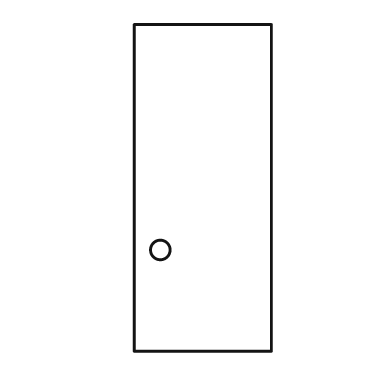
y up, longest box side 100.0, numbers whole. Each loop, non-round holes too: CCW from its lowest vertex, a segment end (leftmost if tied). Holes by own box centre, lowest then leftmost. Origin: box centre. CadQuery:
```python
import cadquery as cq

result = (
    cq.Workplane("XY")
    .moveTo(-21.0, -50.0)
    .lineTo(21.0, -50.0)
    .lineTo(21.0, 50.0)
    .lineTo(-21.0, 50.0)
    .close()
    .moveTo(-13.0, -19.0)
    .circle(3.0)
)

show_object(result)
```